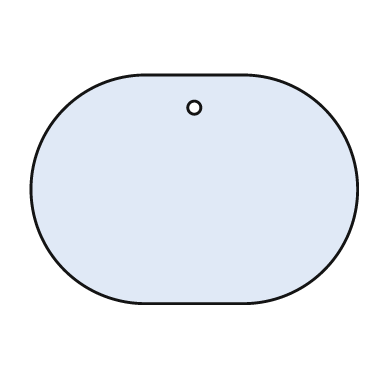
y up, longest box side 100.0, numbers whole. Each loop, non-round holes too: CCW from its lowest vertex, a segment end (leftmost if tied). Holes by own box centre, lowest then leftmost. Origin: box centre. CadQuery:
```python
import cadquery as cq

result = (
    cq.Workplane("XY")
    .moveTo(-15.0, -35.0)
    .lineTo(15.0, -35.0)
    .threePointArc((50.0, 0.0), (15.0, 35.0))
    .lineTo(-15.0, 35.0)
    .threePointArc((-50.0, 0.0), (-15.0, -35.0))
    .close()
    .moveTo(0.0, 25.0)
    .circle(2.0)
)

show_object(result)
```